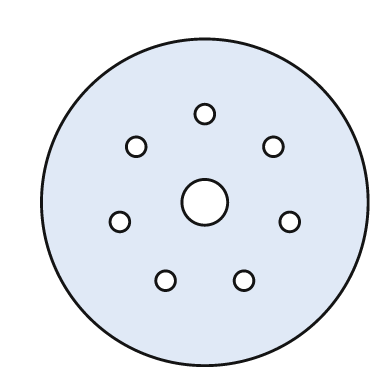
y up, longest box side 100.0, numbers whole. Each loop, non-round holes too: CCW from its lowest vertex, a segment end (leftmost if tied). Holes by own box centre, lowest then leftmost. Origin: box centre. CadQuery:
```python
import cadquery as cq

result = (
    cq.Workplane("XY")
    .moveTo(0.0, 0.0)
    .circle(50.0)
    .moveTo(-12.0, -24.0)
    .circle(3.0)
    .moveTo(12.0, -24.0)
    .circle(3.0)
    .moveTo(-26.0, -6.0)
    .circle(3.0)
    .moveTo(26.0, -6.0)
    .circle(3.0)
    .moveTo(0.0, 0.0)
    .circle(7.0)
    .moveTo(-21.0, 17.0)
    .circle(3.0)
    .moveTo(21.0, 17.0)
    .circle(3.0)
    .moveTo(0.0, 27.0)
    .circle(3.0)
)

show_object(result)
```